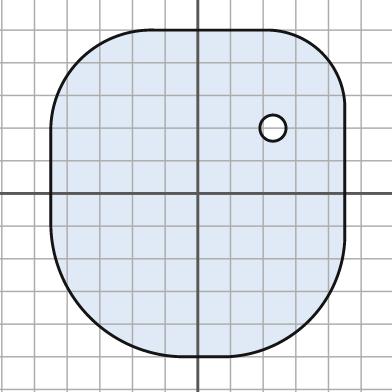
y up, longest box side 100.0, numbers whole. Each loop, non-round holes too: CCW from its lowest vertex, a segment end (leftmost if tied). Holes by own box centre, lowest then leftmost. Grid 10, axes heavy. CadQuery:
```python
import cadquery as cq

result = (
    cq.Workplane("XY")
    .moveTo(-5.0, -50.0)
    .lineTo(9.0, -50.0)
    .threePointArc((34.0, -39.0), (45.0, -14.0))
    .lineTo(45.0, 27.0)
    .threePointArc((38.0, 43.0), (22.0, 50.0))
    .lineTo(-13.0, 50.0)
    .threePointArc((-36.0, 41.0), (-45.0, 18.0))
    .lineTo(-45.0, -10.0)
    .threePointArc((-33.0, -38.0), (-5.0, -50.0))
    .close()
    .moveTo(23.0, 20.0)
    .circle(4.0)
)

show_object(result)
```